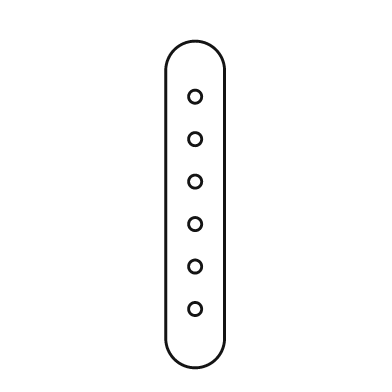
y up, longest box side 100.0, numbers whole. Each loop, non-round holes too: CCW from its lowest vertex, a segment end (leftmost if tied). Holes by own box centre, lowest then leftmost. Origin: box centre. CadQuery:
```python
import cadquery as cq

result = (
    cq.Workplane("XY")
    .moveTo(-9.0, -41.0)
    .threePointArc((0.0, -50.0), (9.0, -41.0))
    .lineTo(9.0, 41.0)
    .threePointArc((0.0, 50.0), (-9.0, 41.0))
    .close()
    .moveTo(0.0, -32.0)
    .circle(2.0)
    .moveTo(0.0, -19.0)
    .circle(2.0)
    .moveTo(0.0, -6.0)
    .circle(2.0)
    .moveTo(0.0, 7.0)
    .circle(2.0)
    .moveTo(0.0, 20.0)
    .circle(2.0)
    .moveTo(0.0, 33.0)
    .circle(2.0)
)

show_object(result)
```